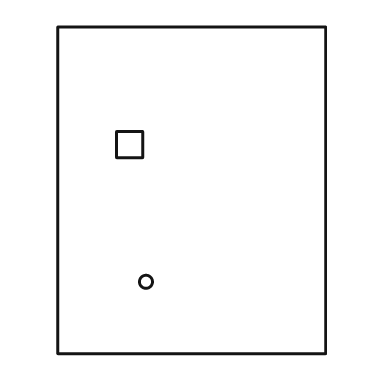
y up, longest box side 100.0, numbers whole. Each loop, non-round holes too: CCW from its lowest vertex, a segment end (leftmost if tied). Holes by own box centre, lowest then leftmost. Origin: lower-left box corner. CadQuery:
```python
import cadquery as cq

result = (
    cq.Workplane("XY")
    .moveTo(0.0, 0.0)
    .lineTo(82.0, 0.0)
    .lineTo(82.0, 100.0)
    .lineTo(0.0, 100.0)
    .close()
    .moveTo(27.0, 22.0)
    .circle(2.0)
    .moveTo(18.0, 60.0)
    .lineTo(26.0, 60.0)
    .lineTo(26.0, 68.0)
    .lineTo(18.0, 68.0)
    .close()
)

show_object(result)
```